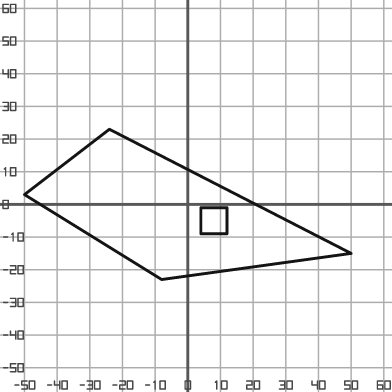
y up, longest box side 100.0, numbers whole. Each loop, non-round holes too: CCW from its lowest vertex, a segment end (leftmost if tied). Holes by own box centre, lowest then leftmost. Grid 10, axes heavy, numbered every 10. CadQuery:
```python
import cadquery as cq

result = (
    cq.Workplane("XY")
    .moveTo(-8.0, -23.0)
    .lineTo(50.0, -15.0)
    .lineTo(-24.0, 23.0)
    .lineTo(-50.0, 3.0)
    .close()
    .moveTo(4.0, -9.0)
    .lineTo(12.0, -9.0)
    .lineTo(12.0, -1.0)
    .lineTo(4.0, -1.0)
    .close()
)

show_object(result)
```